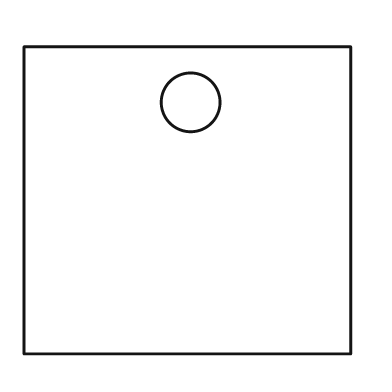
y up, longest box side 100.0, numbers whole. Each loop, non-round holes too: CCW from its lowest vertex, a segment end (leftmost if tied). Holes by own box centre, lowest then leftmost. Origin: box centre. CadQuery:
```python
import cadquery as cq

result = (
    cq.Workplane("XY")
    .moveTo(-50.0, -47.0)
    .lineTo(50.0, -47.0)
    .lineTo(50.0, 47.0)
    .lineTo(-50.0, 47.0)
    .close()
    .moveTo(1.0, 30.0)
    .circle(9.0)
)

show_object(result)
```